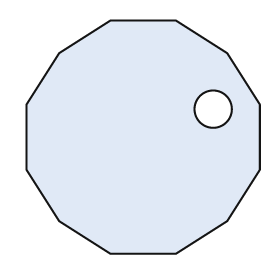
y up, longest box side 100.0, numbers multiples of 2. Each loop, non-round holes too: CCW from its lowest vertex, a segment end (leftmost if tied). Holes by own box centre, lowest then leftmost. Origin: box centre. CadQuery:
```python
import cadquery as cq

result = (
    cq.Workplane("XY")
    .moveTo(-14.0, -50.0)
    .lineTo(14.0, -50.0)
    .lineTo(36.0, -36.0)
    .lineTo(50.0, -14.0)
    .lineTo(50.0, 14.0)
    .lineTo(36.0, 36.0)
    .lineTo(14.0, 50.0)
    .lineTo(-14.0, 50.0)
    .lineTo(-36.0, 36.0)
    .lineTo(-50.0, 14.0)
    .lineTo(-50.0, -14.0)
    .lineTo(-36.0, -36.0)
    .close()
    .moveTo(30.0, 12.0)
    .circle(8.0)
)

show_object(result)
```